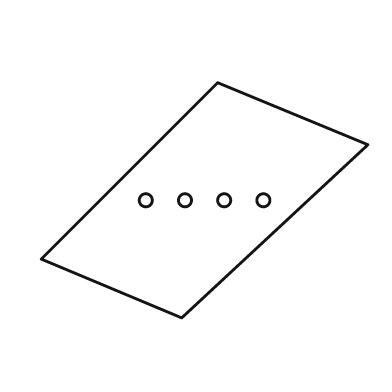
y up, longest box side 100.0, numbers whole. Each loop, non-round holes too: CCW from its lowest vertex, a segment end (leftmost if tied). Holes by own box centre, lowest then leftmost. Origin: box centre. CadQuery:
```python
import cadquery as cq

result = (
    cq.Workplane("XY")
    .moveTo(-7.0, -36.0)
    .lineTo(50.0, 17.0)
    .lineTo(4.0, 36.0)
    .lineTo(-50.0, -18.0)
    .close()
    .moveTo(-18.0, 0.0)
    .circle(2.0)
    .moveTo(-6.0, 0.0)
    .circle(2.0)
    .moveTo(6.0, 0.0)
    .circle(2.0)
    .moveTo(18.0, 0.0)
    .circle(2.0)
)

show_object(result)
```